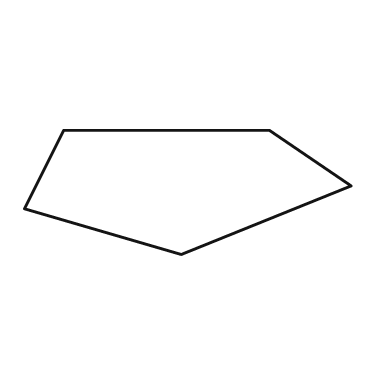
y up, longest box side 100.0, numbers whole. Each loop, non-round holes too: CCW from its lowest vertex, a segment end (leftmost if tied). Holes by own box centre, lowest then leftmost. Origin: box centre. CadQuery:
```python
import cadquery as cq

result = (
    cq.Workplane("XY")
    .moveTo(-2.0, -19.0)
    .lineTo(50.0, 2.0)
    .lineTo(25.0, 19.0)
    .lineTo(-38.0, 19.0)
    .lineTo(-50.0, -5.0)
    .close()
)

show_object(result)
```